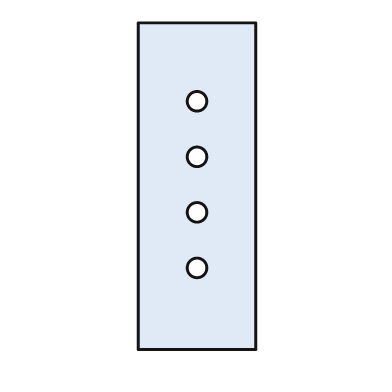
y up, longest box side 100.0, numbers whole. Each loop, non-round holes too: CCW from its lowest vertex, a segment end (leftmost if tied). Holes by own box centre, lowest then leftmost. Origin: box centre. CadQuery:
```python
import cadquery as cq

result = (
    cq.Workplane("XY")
    .moveTo(-18.0, -50.0)
    .lineTo(18.0, -50.0)
    .lineTo(18.0, 50.0)
    .lineTo(-18.0, 50.0)
    .close()
    .moveTo(0.0, -25.0)
    .circle(3.0)
    .moveTo(0.0, -8.0)
    .circle(3.0)
    .moveTo(0.0, 9.0)
    .circle(3.0)
    .moveTo(0.0, 26.0)
    .circle(3.0)
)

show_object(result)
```